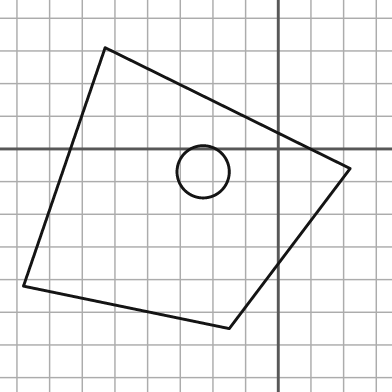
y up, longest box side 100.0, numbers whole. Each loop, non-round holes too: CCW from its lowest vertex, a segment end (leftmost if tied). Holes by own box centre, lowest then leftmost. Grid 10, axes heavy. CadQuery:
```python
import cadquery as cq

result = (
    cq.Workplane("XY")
    .moveTo(-15.0, -55.0)
    .lineTo(22.0, -6.0)
    .lineTo(-53.0, 31.0)
    .lineTo(-78.0, -42.0)
    .close()
    .moveTo(-23.0, -7.0)
    .circle(8.0)
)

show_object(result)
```